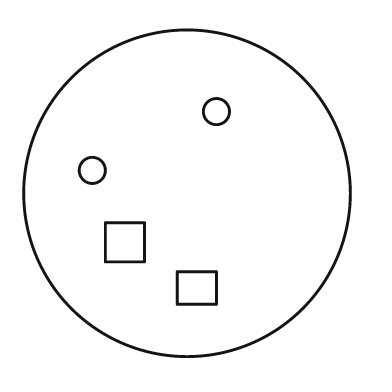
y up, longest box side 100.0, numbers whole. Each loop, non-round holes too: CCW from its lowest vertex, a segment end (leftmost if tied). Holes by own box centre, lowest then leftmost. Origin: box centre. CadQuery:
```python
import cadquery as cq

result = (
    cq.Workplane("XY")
    .moveTo(0.0, 0.0)
    .circle(50.0)
    .moveTo(-3.0, -34.0)
    .lineTo(9.0, -34.0)
    .lineTo(9.0, -24.0)
    .lineTo(-3.0, -24.0)
    .close()
    .moveTo(-25.0, -21.0)
    .lineTo(-13.0, -21.0)
    .lineTo(-13.0, -9.0)
    .lineTo(-25.0, -9.0)
    .close()
    .moveTo(-29.0, 7.0)
    .circle(4.0)
    .moveTo(9.0, 25.0)
    .circle(4.0)
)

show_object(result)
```